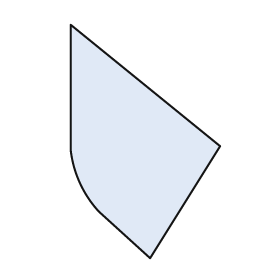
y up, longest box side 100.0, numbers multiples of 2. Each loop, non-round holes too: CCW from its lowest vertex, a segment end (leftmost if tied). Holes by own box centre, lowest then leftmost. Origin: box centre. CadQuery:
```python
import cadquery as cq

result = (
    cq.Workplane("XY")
    .moveTo(2.0, -50.0)
    .lineTo(32.0, -2.0)
    .lineTo(-32.0, 50.0)
    .lineTo(-32.0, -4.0)
    .threePointArc((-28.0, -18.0), (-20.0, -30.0))
    .close()
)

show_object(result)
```